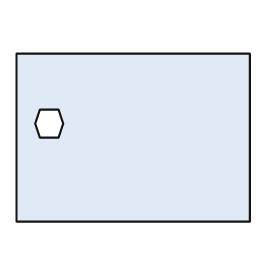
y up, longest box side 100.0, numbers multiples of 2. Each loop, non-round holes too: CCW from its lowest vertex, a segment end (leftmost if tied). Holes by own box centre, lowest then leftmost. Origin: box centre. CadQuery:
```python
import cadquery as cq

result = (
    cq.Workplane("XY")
    .moveTo(-50.0, -36.0)
    .lineTo(50.0, -36.0)
    .lineTo(50.0, 36.0)
    .lineTo(-50.0, 36.0)
    .close()
    .moveTo(-40.0, 0.0)
    .lineTo(-32.0, 0.0)
    .lineTo(-30.0, 6.0)
    .lineTo(-32.0, 12.0)
    .lineTo(-40.0, 12.0)
    .lineTo(-42.0, 6.0)
    .close()
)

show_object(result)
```